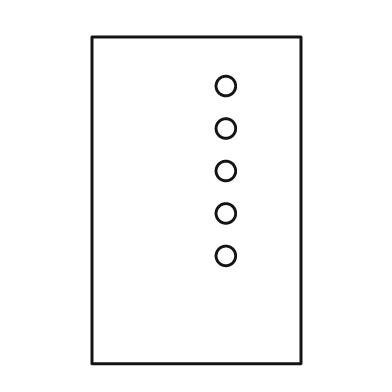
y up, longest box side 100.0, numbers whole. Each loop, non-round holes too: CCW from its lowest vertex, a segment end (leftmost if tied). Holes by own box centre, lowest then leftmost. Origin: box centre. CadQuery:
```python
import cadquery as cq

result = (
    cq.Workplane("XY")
    .moveTo(-32.0, -50.0)
    .lineTo(32.0, -50.0)
    .lineTo(32.0, 50.0)
    .lineTo(-32.0, 50.0)
    .close()
    .moveTo(9.0, -17.0)
    .circle(3.0)
    .moveTo(9.0, -4.0)
    .circle(3.0)
    .moveTo(9.0, 9.0)
    .circle(3.0)
    .moveTo(9.0, 22.0)
    .circle(3.0)
    .moveTo(9.0, 35.0)
    .circle(3.0)
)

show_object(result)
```